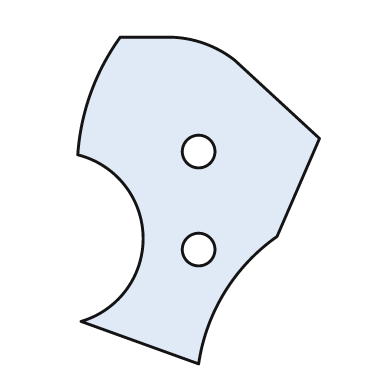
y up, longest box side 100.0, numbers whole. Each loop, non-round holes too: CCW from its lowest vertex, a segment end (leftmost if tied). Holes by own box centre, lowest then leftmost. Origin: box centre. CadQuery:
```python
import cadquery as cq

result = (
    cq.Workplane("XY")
    .moveTo(0.0, -50.0)
    .threePointArc((8.0, -28.0), (24.0, -11.0))
    .lineTo(37.0, 19.0)
    .lineTo(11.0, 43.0)
    .threePointArc((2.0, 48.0), (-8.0, 50.0))
    .lineTo(-24.0, 50.0)
    .threePointArc((-33.0, 33.0), (-37.0, 14.0))
    .threePointArc((-17.0, -11.0), (-36.0, -37.0))
    .close()
    .moveTo(0.0, -15.0)
    .circle(5.0)
    .moveTo(0.0, 15.0)
    .circle(5.0)
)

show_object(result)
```